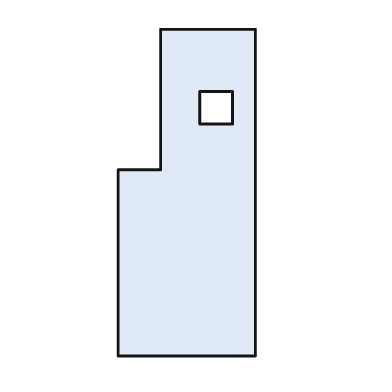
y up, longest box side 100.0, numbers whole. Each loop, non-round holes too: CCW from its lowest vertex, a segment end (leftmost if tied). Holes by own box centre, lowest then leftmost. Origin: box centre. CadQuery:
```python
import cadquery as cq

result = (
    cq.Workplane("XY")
    .moveTo(-21.0, -50.0)
    .lineTo(21.0, -50.0)
    .lineTo(21.0, 50.0)
    .lineTo(-8.0, 50.0)
    .lineTo(-8.0, 7.0)
    .lineTo(-21.0, 7.0)
    .close()
    .moveTo(4.0, 21.0)
    .lineTo(14.0, 21.0)
    .lineTo(14.0, 31.0)
    .lineTo(4.0, 31.0)
    .close()
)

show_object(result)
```